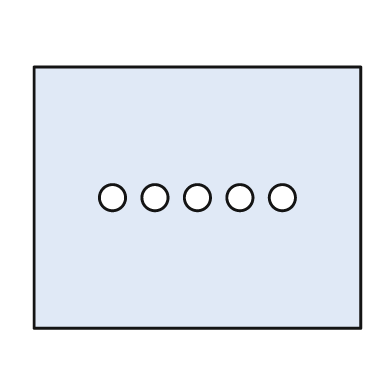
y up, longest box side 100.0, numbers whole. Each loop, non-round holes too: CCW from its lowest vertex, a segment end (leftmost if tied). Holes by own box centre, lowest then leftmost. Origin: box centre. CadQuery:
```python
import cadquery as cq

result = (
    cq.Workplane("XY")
    .moveTo(-50.0, -40.0)
    .lineTo(50.0, -40.0)
    .lineTo(50.0, 40.0)
    .lineTo(-50.0, 40.0)
    .close()
    .moveTo(-26.0, 0.0)
    .circle(4.0)
    .moveTo(-13.0, 0.0)
    .circle(4.0)
    .moveTo(0.0, 0.0)
    .circle(4.0)
    .moveTo(13.0, 0.0)
    .circle(4.0)
    .moveTo(26.0, 0.0)
    .circle(4.0)
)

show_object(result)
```